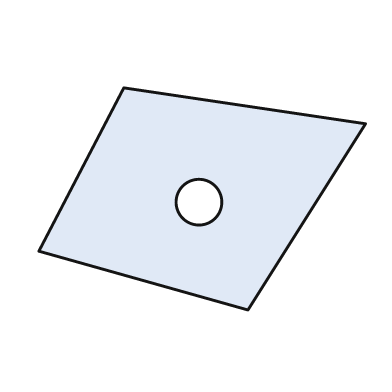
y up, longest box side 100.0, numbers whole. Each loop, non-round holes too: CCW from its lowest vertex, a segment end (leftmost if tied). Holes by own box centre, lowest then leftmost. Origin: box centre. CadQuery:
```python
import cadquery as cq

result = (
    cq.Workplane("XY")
    .moveTo(14.0, -34.0)
    .lineTo(50.0, 23.0)
    .lineTo(-24.0, 34.0)
    .lineTo(-50.0, -16.0)
    .close()
    .moveTo(-1.0, -1.0)
    .circle(7.0)
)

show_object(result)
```